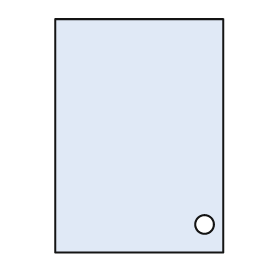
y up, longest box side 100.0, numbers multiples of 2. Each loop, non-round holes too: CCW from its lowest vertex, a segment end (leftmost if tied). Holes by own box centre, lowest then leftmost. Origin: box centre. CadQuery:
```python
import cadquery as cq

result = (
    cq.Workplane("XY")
    .moveTo(-36.0, -50.0)
    .lineTo(36.0, -50.0)
    .lineTo(36.0, 50.0)
    .lineTo(-36.0, 50.0)
    .close()
    .moveTo(28.0, -38.0)
    .circle(4.0)
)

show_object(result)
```